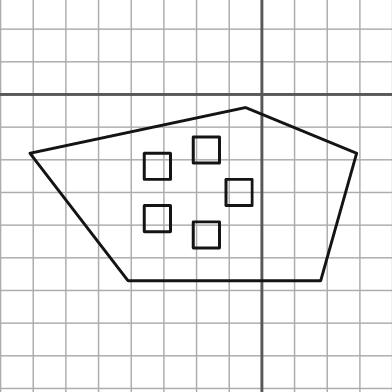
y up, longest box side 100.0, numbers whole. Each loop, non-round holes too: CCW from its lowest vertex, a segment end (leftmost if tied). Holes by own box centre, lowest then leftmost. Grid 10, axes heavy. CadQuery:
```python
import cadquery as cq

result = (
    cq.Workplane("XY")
    .moveTo(-41.0, -57.0)
    .lineTo(18.0, -57.0)
    .lineTo(29.0, -18.0)
    .lineTo(-5.0, -4.0)
    .lineTo(-71.0, -18.0)
    .close()
    .moveTo(-21.0, -47.0)
    .lineTo(-13.0, -47.0)
    .lineTo(-13.0, -39.0)
    .lineTo(-21.0, -39.0)
    .close()
    .moveTo(-36.0, -42.0)
    .lineTo(-28.0, -42.0)
    .lineTo(-28.0, -34.0)
    .lineTo(-36.0, -34.0)
    .close()
    .moveTo(-11.0, -34.0)
    .lineTo(-3.0, -34.0)
    .lineTo(-3.0, -26.0)
    .lineTo(-11.0, -26.0)
    .close()
    .moveTo(-36.0, -26.0)
    .lineTo(-28.0, -26.0)
    .lineTo(-28.0, -18.0)
    .lineTo(-36.0, -18.0)
    .close()
    .moveTo(-21.0, -21.0)
    .lineTo(-13.0, -21.0)
    .lineTo(-13.0, -13.0)
    .lineTo(-21.0, -13.0)
    .close()
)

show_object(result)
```